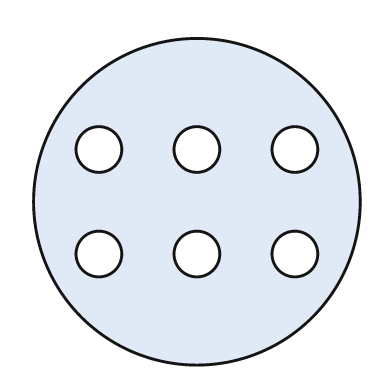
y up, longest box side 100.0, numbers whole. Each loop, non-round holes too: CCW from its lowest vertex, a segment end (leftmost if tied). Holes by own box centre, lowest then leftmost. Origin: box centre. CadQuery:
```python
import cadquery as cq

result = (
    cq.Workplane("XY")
    .moveTo(0.0, 0.0)
    .circle(50.0)
    .moveTo(-30.0, -16.0)
    .circle(7.0)
    .moveTo(0.0, -16.0)
    .circle(7.0)
    .moveTo(30.0, -16.0)
    .circle(7.0)
    .moveTo(-30.0, 16.0)
    .circle(7.0)
    .moveTo(0.0, 16.0)
    .circle(7.0)
    .moveTo(30.0, 16.0)
    .circle(7.0)
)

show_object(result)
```